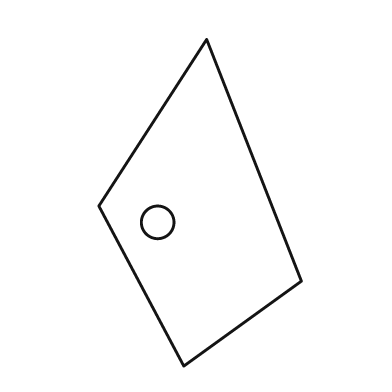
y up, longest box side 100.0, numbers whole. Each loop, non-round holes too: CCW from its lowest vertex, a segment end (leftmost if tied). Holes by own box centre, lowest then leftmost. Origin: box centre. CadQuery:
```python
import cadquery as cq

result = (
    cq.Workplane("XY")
    .moveTo(-5.0, -50.0)
    .lineTo(31.0, -24.0)
    .lineTo(2.0, 50.0)
    .lineTo(-31.0, -1.0)
    .close()
    .moveTo(-13.0, -6.0)
    .circle(5.0)
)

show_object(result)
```